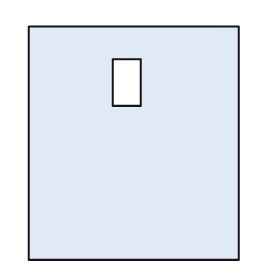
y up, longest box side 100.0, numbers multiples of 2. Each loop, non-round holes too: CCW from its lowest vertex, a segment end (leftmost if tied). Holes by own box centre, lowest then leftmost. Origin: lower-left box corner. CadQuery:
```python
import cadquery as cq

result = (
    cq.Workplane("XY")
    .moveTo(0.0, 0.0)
    .lineTo(90.0, 0.0)
    .lineTo(90.0, 100.0)
    .lineTo(0.0, 100.0)
    .close()
    .moveTo(36.0, 66.0)
    .lineTo(48.0, 66.0)
    .lineTo(48.0, 86.0)
    .lineTo(36.0, 86.0)
    .close()
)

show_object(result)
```